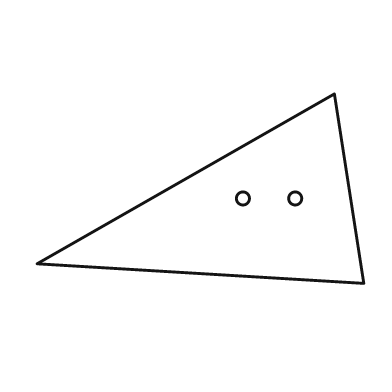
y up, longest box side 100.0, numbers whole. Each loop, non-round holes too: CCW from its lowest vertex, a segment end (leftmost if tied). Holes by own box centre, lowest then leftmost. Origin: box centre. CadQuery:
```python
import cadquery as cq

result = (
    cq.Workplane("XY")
    .moveTo(50.0, -29.0)
    .lineTo(41.0, 29.0)
    .lineTo(-50.0, -23.0)
    .close()
    .moveTo(13.0, -3.0)
    .circle(2.0)
    .moveTo(29.0, -3.0)
    .circle(2.0)
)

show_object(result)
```